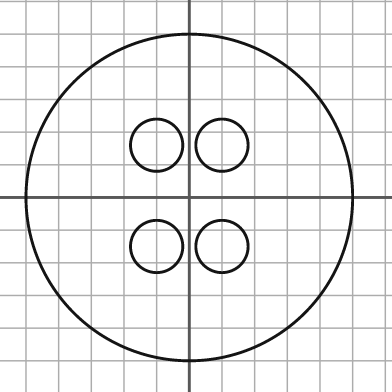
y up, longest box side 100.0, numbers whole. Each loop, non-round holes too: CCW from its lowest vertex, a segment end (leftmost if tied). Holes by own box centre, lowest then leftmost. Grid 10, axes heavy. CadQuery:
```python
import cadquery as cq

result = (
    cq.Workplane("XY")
    .moveTo(0.0, 0.0)
    .circle(50.0)
    .moveTo(-10.0, -15.0)
    .circle(8.0)
    .moveTo(10.0, -15.0)
    .circle(8.0)
    .moveTo(-10.0, 16.0)
    .circle(8.0)
    .moveTo(10.0, 16.0)
    .circle(8.0)
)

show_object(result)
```